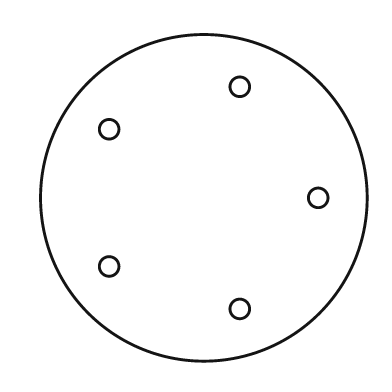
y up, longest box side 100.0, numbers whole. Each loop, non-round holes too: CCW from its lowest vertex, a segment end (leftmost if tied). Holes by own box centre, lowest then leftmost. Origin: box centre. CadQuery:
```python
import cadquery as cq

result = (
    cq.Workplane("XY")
    .moveTo(0.0, 0.0)
    .circle(50.0)
    .moveTo(11.0, -34.0)
    .circle(3.0)
    .moveTo(-29.0, -21.0)
    .circle(3.0)
    .moveTo(35.0, 0.0)
    .circle(3.0)
    .moveTo(-29.0, 21.0)
    .circle(3.0)
    .moveTo(11.0, 34.0)
    .circle(3.0)
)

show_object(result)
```